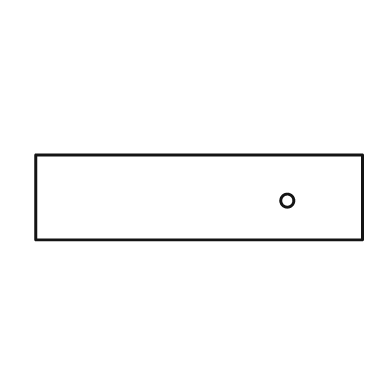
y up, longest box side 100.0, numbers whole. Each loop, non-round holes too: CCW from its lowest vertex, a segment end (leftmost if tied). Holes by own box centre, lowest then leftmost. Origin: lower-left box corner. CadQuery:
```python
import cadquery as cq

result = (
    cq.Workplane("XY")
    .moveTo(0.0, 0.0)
    .lineTo(100.0, 0.0)
    .lineTo(100.0, 26.0)
    .lineTo(0.0, 26.0)
    .close()
    .moveTo(77.0, 12.0)
    .circle(2.0)
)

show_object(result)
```